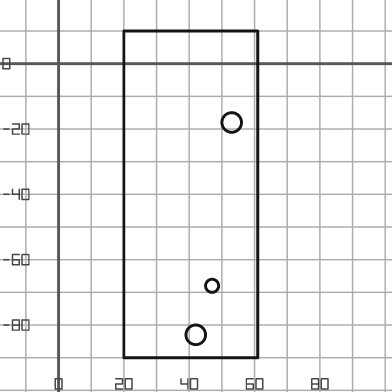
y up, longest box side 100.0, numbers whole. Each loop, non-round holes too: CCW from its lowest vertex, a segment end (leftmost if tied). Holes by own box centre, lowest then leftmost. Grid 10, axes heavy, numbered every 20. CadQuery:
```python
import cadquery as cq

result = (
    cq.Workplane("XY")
    .moveTo(20.0, -90.0)
    .lineTo(61.0, -90.0)
    .lineTo(61.0, 10.0)
    .lineTo(20.0, 10.0)
    .close()
    .moveTo(42.0, -83.0)
    .circle(3.0)
    .moveTo(47.0, -68.0)
    .circle(2.0)
    .moveTo(53.0, -18.0)
    .circle(3.0)
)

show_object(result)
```